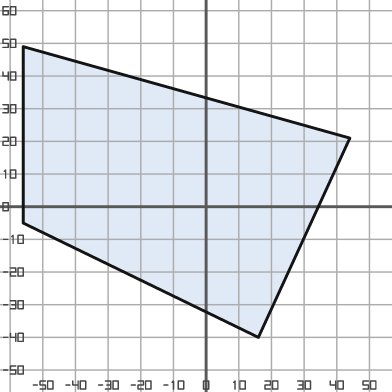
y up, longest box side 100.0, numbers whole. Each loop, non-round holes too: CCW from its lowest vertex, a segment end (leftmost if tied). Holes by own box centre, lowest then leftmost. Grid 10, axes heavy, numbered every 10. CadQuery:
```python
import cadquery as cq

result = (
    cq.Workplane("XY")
    .moveTo(16.0, -40.0)
    .lineTo(44.0, 21.0)
    .lineTo(-56.0, 49.0)
    .lineTo(-56.0, -5.0)
    .close()
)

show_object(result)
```